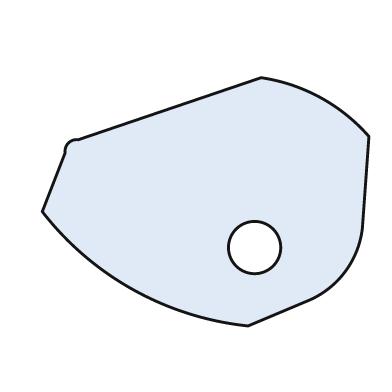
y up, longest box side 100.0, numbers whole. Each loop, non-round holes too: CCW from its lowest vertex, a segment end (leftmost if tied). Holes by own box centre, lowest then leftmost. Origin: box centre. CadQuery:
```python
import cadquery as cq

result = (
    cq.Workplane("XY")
    .moveTo(13.0, -38.0)
    .lineTo(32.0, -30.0)
    .threePointArc((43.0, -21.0), (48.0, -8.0))
    .lineTo(50.0, 20.0)
    .threePointArc((35.0, 32.0), (17.0, 38.0))
    .lineTo(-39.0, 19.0)
    .threePointArc((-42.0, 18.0), (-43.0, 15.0))
    .lineTo(-50.0, -3.0)
    .threePointArc((-22.0, -27.0), (13.0, -38.0))
    .close()
    .moveTo(15.0, -14.0)
    .circle(8.0)
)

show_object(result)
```